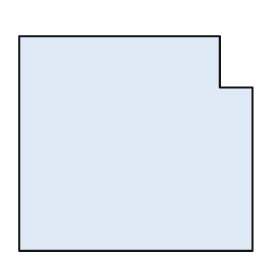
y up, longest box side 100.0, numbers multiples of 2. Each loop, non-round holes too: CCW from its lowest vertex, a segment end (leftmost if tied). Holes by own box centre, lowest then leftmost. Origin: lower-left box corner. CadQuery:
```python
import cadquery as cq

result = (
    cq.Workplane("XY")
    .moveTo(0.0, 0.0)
    .lineTo(100.0, 0.0)
    .lineTo(100.0, 70.0)
    .lineTo(86.0, 70.0)
    .lineTo(86.0, 92.0)
    .lineTo(0.0, 92.0)
    .close()
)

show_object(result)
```